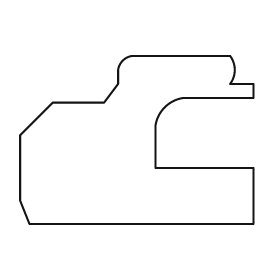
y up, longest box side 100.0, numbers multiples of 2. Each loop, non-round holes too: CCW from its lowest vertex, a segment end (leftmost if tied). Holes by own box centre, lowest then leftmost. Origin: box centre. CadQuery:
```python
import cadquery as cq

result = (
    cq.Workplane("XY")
    .moveTo(-46.0, -36.0)
    .lineTo(50.0, -36.0)
    .lineTo(50.0, -12.0)
    .lineTo(8.0, -12.0)
    .lineTo(8.0, 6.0)
    .threePointArc((12.0, 14.0), (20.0, 18.0))
    .lineTo(50.0, 18.0)
    .lineTo(50.0, 24.0)
    .lineTo(40.0, 24.0)
    .threePointArc((42.0, 30.0), (40.0, 36.0))
    .lineTo(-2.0, 36.0)
    .threePointArc((-6.0, 34.0), (-8.0, 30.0))
    .lineTo(-8.0, 24.0)
    .lineTo(-14.0, 16.0)
    .lineTo(-36.0, 16.0)
    .lineTo(-50.0, 2.0)
    .lineTo(-50.0, -26.0)
    .close()
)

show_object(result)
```